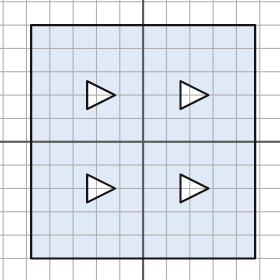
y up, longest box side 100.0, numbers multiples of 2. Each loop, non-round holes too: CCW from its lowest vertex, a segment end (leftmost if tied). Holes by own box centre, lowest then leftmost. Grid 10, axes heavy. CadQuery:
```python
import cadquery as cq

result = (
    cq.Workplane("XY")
    .moveTo(-48.0, -50.0)
    .lineTo(48.0, -50.0)
    .lineTo(48.0, 50.0)
    .lineTo(-48.0, 50.0)
    .close()
    .moveTo(-24.0, -26.0)
    .lineTo(-12.0, -20.0)
    .lineTo(-24.0, -14.0)
    .close()
    .moveTo(16.0, -26.0)
    .lineTo(28.0, -20.0)
    .lineTo(16.0, -14.0)
    .close()
    .moveTo(-24.0, 14.0)
    .lineTo(-12.0, 20.0)
    .lineTo(-24.0, 26.0)
    .close()
    .moveTo(16.0, 14.0)
    .lineTo(28.0, 20.0)
    .lineTo(16.0, 26.0)
    .close()
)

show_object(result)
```